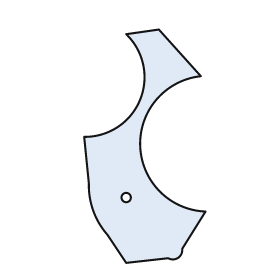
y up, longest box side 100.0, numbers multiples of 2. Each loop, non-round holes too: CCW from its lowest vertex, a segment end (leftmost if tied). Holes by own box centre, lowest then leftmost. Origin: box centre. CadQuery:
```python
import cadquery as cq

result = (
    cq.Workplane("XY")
    .moveTo(-8.0, -50.0)
    .lineTo(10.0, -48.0)
    .threePointArc((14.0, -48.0), (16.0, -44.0))
    .lineTo(26.0, -28.0)
    .threePointArc((-2.0, 0.0), (24.0, 30.0))
    .lineTo(6.0, 50.0)
    .lineTo(-8.0, 48.0)
    .threePointArc((-2.0, 20.0), (-26.0, 4.0))
    .lineTo(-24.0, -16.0)
    .threePointArc((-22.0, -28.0), (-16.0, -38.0))
    .close()
    .moveTo(-8.0, -22.0)
    .circle(2.0)
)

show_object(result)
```